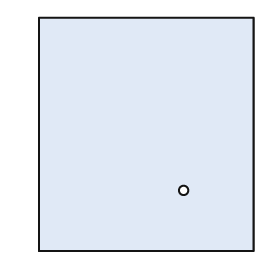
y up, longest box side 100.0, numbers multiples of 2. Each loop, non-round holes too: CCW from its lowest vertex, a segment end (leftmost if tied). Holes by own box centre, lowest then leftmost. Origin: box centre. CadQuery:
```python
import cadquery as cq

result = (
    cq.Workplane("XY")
    .moveTo(-46.0, -50.0)
    .lineTo(46.0, -50.0)
    .lineTo(46.0, 50.0)
    .lineTo(-46.0, 50.0)
    .close()
    .moveTo(16.0, -24.0)
    .circle(2.0)
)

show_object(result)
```